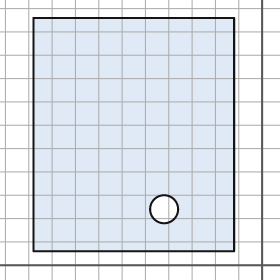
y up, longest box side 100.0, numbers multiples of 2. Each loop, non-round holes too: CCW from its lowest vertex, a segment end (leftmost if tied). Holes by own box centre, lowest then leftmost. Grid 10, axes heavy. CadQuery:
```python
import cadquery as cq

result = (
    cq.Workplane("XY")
    .moveTo(-98.0, 6.0)
    .lineTo(-12.0, 6.0)
    .lineTo(-12.0, 106.0)
    .lineTo(-98.0, 106.0)
    .close()
    .moveTo(-42.0, 24.0)
    .circle(6.0)
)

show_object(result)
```